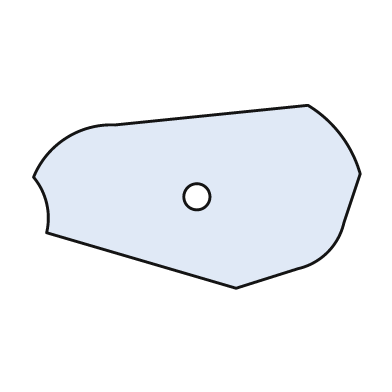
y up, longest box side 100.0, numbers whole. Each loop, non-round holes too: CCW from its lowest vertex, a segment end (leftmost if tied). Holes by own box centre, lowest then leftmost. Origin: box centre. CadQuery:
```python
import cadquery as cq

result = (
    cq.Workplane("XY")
    .moveTo(12.0, -28.0)
    .lineTo(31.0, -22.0)
    .threePointArc((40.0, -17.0), (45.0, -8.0))
    .lineTo(50.0, 7.0)
    .threePointArc((44.0, 19.0), (34.0, 28.0))
    .lineTo(-25.0, 22.0)
    .threePointArc((-40.0, 18.0), (-50.0, 6.0))
    .threePointArc((-46.0, -2.0), (-46.0, -11.0))
    .close()
    .moveTo(0.0, 0.0)
    .circle(4.0)
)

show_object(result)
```